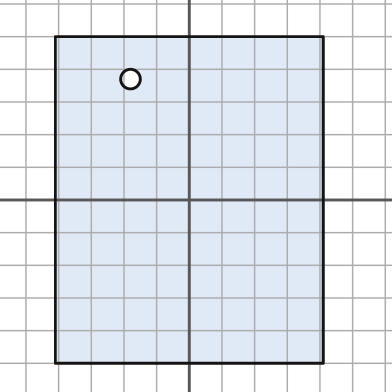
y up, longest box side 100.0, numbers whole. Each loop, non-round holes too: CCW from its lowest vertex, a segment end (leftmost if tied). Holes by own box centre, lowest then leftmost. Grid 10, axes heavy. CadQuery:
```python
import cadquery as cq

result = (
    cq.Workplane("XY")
    .moveTo(-41.0, -50.0)
    .lineTo(41.0, -50.0)
    .lineTo(41.0, 50.0)
    .lineTo(-41.0, 50.0)
    .close()
    .moveTo(-18.0, 37.0)
    .circle(3.0)
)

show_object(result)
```